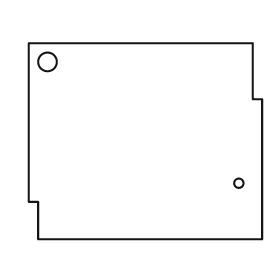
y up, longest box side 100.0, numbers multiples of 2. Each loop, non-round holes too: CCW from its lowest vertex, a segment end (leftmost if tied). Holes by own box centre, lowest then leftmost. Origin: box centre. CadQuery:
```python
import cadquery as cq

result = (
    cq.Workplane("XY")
    .moveTo(-46.0, -42.0)
    .lineTo(50.0, -42.0)
    .lineTo(50.0, 18.0)
    .lineTo(46.0, 18.0)
    .lineTo(46.0, 42.0)
    .lineTo(-50.0, 42.0)
    .lineTo(-50.0, -26.0)
    .lineTo(-46.0, -26.0)
    .close()
    .moveTo(40.0, -18.0)
    .circle(2.0)
    .moveTo(-42.0, 34.0)
    .circle(4.0)
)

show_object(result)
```